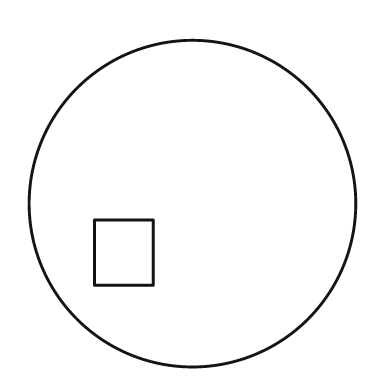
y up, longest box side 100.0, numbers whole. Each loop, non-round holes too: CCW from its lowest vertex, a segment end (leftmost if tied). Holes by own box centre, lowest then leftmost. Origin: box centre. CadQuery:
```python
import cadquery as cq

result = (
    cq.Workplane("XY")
    .moveTo(0.0, 0.0)
    .circle(50.0)
    .moveTo(-30.0, -25.0)
    .lineTo(-12.0, -25.0)
    .lineTo(-12.0, -5.0)
    .lineTo(-30.0, -5.0)
    .close()
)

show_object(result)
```